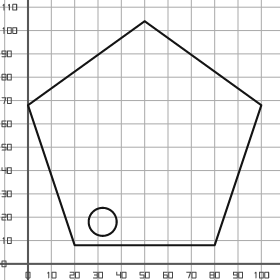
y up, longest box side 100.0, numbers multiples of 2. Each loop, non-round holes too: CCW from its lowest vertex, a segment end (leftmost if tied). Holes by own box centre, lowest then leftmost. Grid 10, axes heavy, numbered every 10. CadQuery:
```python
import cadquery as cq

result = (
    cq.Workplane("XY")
    .moveTo(20.0, 8.0)
    .lineTo(80.0, 8.0)
    .lineTo(100.0, 68.0)
    .lineTo(50.0, 104.0)
    .lineTo(0.0, 68.0)
    .close()
    .moveTo(32.0, 18.0)
    .circle(6.0)
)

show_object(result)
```